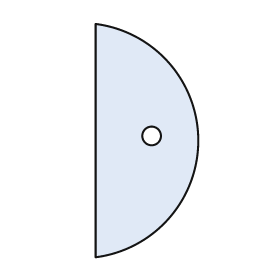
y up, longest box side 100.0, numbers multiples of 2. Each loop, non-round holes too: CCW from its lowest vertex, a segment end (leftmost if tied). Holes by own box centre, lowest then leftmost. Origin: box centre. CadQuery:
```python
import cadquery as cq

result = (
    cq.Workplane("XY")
    .moveTo(-22.0, -50.0)
    .threePointArc((22.0, 0.0), (-22.0, 50.0))
    .close()
    .moveTo(2.0, 2.0)
    .circle(4.0)
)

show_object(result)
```